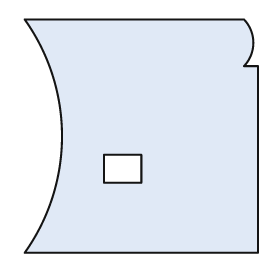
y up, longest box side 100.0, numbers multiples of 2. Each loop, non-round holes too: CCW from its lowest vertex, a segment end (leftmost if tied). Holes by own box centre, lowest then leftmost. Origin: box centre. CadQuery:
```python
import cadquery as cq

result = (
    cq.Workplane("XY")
    .moveTo(-50.0, -50.0)
    .lineTo(50.0, -50.0)
    .lineTo(50.0, 30.0)
    .lineTo(44.0, 30.0)
    .threePointArc((48.0, 40.0), (44.0, 50.0))
    .lineTo(-50.0, 50.0)
    .threePointArc((-34.0, 0.0), (-50.0, -50.0))
    .close()
    .moveTo(-16.0, -20.0)
    .lineTo(0.0, -20.0)
    .lineTo(0.0, -8.0)
    .lineTo(-16.0, -8.0)
    .close()
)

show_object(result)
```